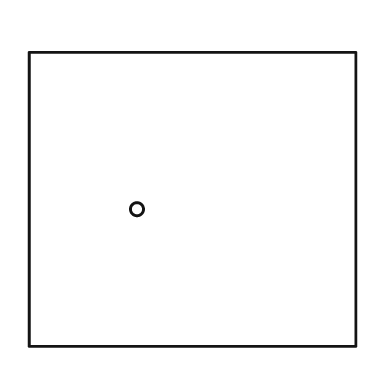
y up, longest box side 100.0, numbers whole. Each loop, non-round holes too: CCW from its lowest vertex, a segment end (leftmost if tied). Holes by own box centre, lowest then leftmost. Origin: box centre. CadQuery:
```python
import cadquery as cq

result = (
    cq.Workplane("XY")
    .moveTo(-50.0, -45.0)
    .lineTo(50.0, -45.0)
    .lineTo(50.0, 45.0)
    .lineTo(-50.0, 45.0)
    .close()
    .moveTo(-17.0, -3.0)
    .circle(2.0)
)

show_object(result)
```